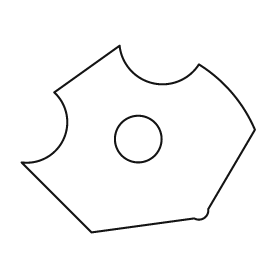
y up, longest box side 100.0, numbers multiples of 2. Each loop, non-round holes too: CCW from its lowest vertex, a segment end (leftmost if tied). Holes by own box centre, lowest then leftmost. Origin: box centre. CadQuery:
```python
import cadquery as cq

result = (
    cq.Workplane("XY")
    .moveTo(-20.0, -40.0)
    .lineTo(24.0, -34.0)
    .threePointArc((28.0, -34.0), (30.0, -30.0))
    .lineTo(50.0, 4.0)
    .threePointArc((40.0, 20.0), (26.0, 32.0))
    .threePointArc((6.0, 24.0), (-8.0, 40.0))
    .lineTo(-36.0, 20.0)
    .threePointArc((-32.0, 0.0), (-50.0, -10.0))
    .close()
    .moveTo(0.0, 0.0)
    .circle(10.0)
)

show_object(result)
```